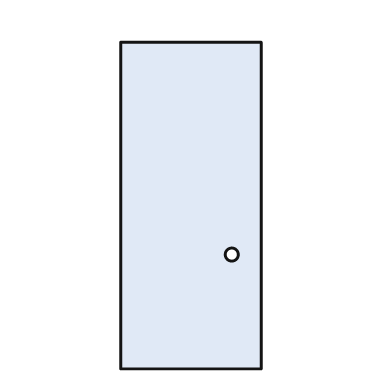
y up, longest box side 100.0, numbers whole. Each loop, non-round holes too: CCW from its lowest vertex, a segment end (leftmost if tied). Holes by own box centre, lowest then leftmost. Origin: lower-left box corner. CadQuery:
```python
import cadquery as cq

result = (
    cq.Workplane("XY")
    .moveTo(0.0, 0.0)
    .lineTo(43.0, 0.0)
    .lineTo(43.0, 100.0)
    .lineTo(0.0, 100.0)
    .close()
    .moveTo(34.0, 35.0)
    .circle(2.0)
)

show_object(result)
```